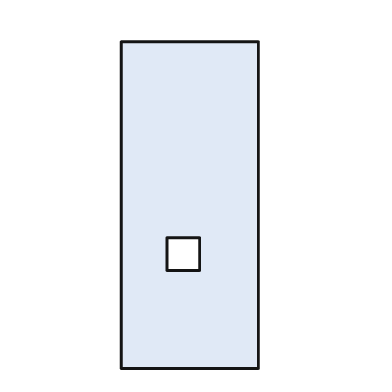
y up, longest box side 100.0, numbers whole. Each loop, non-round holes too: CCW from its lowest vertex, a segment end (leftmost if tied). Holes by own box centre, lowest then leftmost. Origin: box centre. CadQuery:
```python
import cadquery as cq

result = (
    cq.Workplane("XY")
    .moveTo(-21.0, -50.0)
    .lineTo(21.0, -50.0)
    .lineTo(21.0, 50.0)
    .lineTo(-21.0, 50.0)
    .close()
    .moveTo(-7.0, -20.0)
    .lineTo(3.0, -20.0)
    .lineTo(3.0, -10.0)
    .lineTo(-7.0, -10.0)
    .close()
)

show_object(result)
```